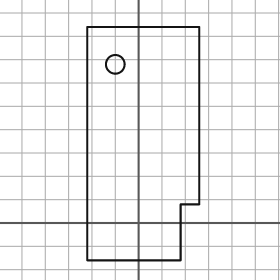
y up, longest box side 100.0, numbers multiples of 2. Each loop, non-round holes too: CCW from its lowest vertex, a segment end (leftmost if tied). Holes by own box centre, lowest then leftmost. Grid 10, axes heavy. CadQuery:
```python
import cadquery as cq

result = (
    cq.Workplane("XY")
    .moveTo(-22.0, -16.0)
    .lineTo(18.0, -16.0)
    .lineTo(18.0, 8.0)
    .lineTo(26.0, 8.0)
    .lineTo(26.0, 84.0)
    .lineTo(-22.0, 84.0)
    .close()
    .moveTo(-10.0, 68.0)
    .circle(4.0)
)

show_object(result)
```